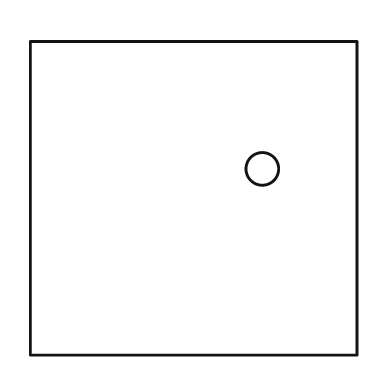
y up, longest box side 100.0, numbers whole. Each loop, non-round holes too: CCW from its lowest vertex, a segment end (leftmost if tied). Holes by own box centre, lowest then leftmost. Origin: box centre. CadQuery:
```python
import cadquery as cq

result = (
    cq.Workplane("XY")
    .moveTo(-50.0, -48.0)
    .lineTo(50.0, -48.0)
    .lineTo(50.0, 48.0)
    .lineTo(-50.0, 48.0)
    .close()
    .moveTo(21.0, 9.0)
    .circle(5.0)
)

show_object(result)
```